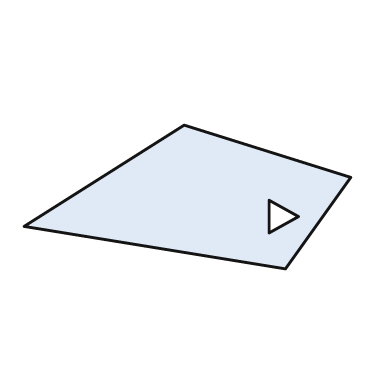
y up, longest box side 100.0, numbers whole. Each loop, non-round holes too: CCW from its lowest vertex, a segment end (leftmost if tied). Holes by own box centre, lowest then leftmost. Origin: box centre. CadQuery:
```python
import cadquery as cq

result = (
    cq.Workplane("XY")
    .moveTo(30.0, -22.0)
    .lineTo(50.0, 6.0)
    .lineTo(-1.0, 22.0)
    .lineTo(-50.0, -9.0)
    .close()
    .moveTo(25.0, -11.0)
    .lineTo(34.0, -6.0)
    .lineTo(25.0, -1.0)
    .close()
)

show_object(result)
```